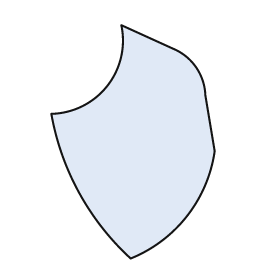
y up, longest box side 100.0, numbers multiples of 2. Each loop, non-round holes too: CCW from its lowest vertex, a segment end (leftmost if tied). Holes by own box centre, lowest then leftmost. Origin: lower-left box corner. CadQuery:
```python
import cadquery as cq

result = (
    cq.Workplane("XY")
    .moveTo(34.0, 0.0)
    .threePointArc((58.0, 18.0), (70.0, 46.0))
    .lineTo(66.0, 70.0)
    .threePointArc((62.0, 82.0), (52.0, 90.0))
    .lineTo(30.0, 100.0)
    .threePointArc((24.0, 74.0), (0.0, 62.0))
    .threePointArc((12.0, 28.0), (34.0, 0.0))
    .close()
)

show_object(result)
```